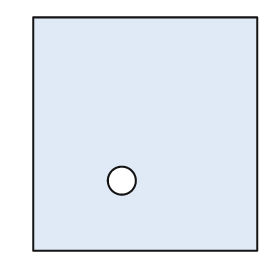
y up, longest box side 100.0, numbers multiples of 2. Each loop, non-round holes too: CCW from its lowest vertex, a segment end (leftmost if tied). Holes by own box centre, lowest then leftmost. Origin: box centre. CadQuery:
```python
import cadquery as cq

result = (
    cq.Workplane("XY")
    .moveTo(-48.0, -50.0)
    .lineTo(48.0, -50.0)
    .lineTo(48.0, 50.0)
    .lineTo(-48.0, 50.0)
    .close()
    .moveTo(-10.0, -20.0)
    .circle(6.0)
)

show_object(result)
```